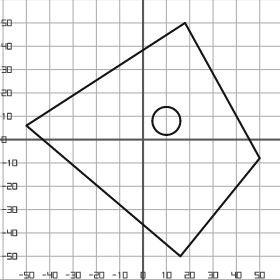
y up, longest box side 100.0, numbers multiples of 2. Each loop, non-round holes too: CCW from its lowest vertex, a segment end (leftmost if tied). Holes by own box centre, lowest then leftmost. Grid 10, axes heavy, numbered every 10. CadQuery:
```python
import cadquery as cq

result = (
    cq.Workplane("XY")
    .moveTo(16.0, -50.0)
    .lineTo(50.0, -8.0)
    .lineTo(18.0, 50.0)
    .lineTo(-50.0, 6.0)
    .close()
    .moveTo(10.0, 8.0)
    .circle(6.0)
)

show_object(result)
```